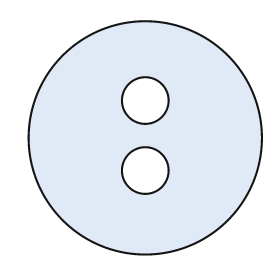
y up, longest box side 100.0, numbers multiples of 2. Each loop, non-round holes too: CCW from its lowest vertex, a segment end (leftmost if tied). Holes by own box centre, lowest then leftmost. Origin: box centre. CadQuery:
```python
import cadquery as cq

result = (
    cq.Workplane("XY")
    .moveTo(0.0, 0.0)
    .circle(50.0)
    .moveTo(0.0, -14.0)
    .circle(10.0)
    .moveTo(0.0, 16.0)
    .circle(10.0)
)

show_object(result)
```